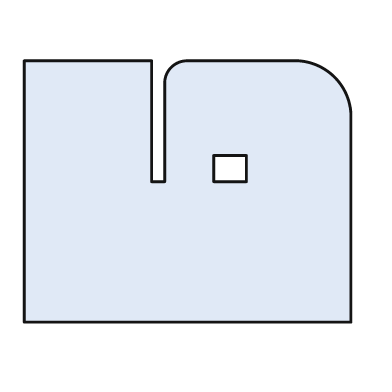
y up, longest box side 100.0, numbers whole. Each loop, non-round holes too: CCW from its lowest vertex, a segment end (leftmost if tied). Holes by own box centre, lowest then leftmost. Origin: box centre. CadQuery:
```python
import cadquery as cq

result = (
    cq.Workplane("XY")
    .moveTo(-50.0, -40.0)
    .lineTo(50.0, -40.0)
    .lineTo(50.0, 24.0)
    .threePointArc((45.0, 35.0), (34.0, 40.0))
    .lineTo(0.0, 40.0)
    .threePointArc((-5.0, 38.0), (-7.0, 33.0))
    .lineTo(-7.0, 3.0)
    .lineTo(-11.0, 3.0)
    .lineTo(-11.0, 40.0)
    .lineTo(-50.0, 40.0)
    .close()
    .moveTo(8.0, 3.0)
    .lineTo(18.0, 3.0)
    .lineTo(18.0, 11.0)
    .lineTo(8.0, 11.0)
    .close()
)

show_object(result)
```